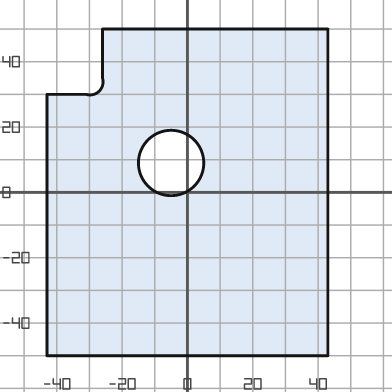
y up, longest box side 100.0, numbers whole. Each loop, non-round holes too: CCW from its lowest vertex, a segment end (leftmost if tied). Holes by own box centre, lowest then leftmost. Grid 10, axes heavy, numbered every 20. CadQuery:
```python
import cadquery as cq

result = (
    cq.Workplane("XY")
    .moveTo(-43.0, -50.0)
    .lineTo(43.0, -50.0)
    .lineTo(43.0, 50.0)
    .lineTo(-26.0, 50.0)
    .lineTo(-26.0, 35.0)
    .threePointArc((-27.0, 31.0), (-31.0, 30.0))
    .lineTo(-43.0, 30.0)
    .close()
    .moveTo(-5.0, 9.0)
    .circle(10.0)
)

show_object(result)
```